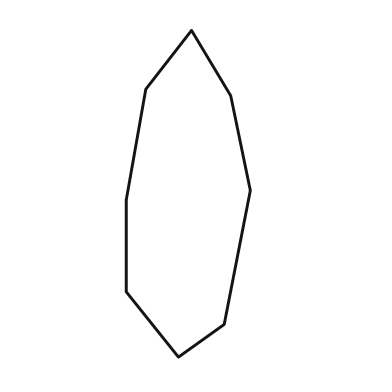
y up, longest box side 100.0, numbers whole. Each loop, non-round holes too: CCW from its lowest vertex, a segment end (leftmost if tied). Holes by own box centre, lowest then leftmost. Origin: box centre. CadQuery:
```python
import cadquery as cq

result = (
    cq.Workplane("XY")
    .moveTo(-3.0, -50.0)
    .lineTo(11.0, -40.0)
    .lineTo(19.0, 1.0)
    .lineTo(13.0, 30.0)
    .lineTo(1.0, 50.0)
    .lineTo(-13.0, 32.0)
    .lineTo(-19.0, -2.0)
    .lineTo(-19.0, -30.0)
    .close()
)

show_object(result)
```